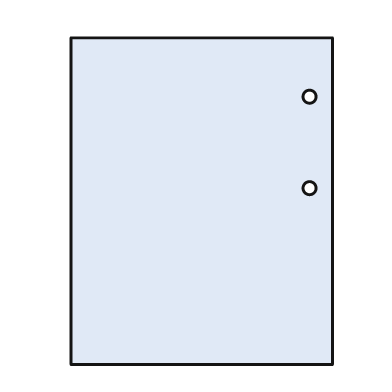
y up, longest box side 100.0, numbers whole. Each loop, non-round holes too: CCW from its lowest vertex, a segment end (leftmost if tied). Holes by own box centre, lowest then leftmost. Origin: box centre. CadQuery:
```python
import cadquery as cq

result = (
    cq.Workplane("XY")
    .moveTo(-40.0, -50.0)
    .lineTo(40.0, -50.0)
    .lineTo(40.0, 50.0)
    .lineTo(-40.0, 50.0)
    .close()
    .moveTo(33.0, 4.0)
    .circle(2.0)
    .moveTo(33.0, 32.0)
    .circle(2.0)
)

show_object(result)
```